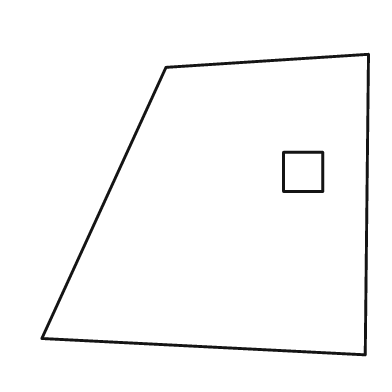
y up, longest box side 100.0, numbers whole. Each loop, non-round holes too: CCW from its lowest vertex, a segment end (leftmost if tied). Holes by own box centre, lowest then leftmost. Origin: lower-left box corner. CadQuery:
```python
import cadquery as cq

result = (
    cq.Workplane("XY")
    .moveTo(99.0, 0.0)
    .lineTo(100.0, 92.0)
    .lineTo(38.0, 88.0)
    .lineTo(0.0, 5.0)
    .close()
    .moveTo(74.0, 50.0)
    .lineTo(86.0, 50.0)
    .lineTo(86.0, 62.0)
    .lineTo(74.0, 62.0)
    .close()
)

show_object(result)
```